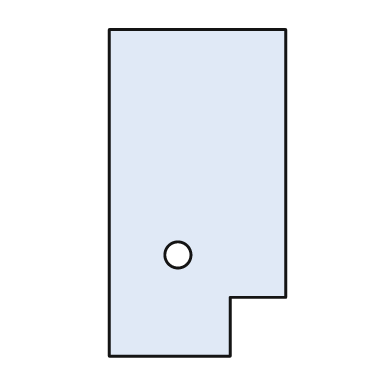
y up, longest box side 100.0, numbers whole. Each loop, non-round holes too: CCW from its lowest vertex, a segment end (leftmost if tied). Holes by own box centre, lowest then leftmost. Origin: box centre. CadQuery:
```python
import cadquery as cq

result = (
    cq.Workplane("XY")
    .moveTo(-27.0, -50.0)
    .lineTo(10.0, -50.0)
    .lineTo(10.0, -32.0)
    .lineTo(27.0, -32.0)
    .lineTo(27.0, 50.0)
    .lineTo(-27.0, 50.0)
    .close()
    .moveTo(-6.0, -19.0)
    .circle(4.0)
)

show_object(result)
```